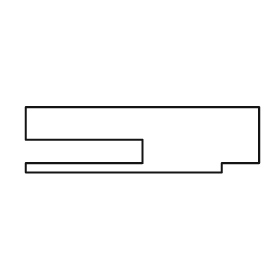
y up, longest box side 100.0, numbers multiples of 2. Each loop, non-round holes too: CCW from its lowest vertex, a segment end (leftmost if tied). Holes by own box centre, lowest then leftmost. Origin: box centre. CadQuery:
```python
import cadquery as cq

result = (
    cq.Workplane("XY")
    .moveTo(-50.0, -14.0)
    .lineTo(34.0, -14.0)
    .lineTo(34.0, -10.0)
    .lineTo(50.0, -10.0)
    .lineTo(50.0, 14.0)
    .lineTo(-50.0, 14.0)
    .lineTo(-50.0, 0.0)
    .lineTo(0.0, 0.0)
    .lineTo(0.0, -10.0)
    .lineTo(-50.0, -10.0)
    .close()
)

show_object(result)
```